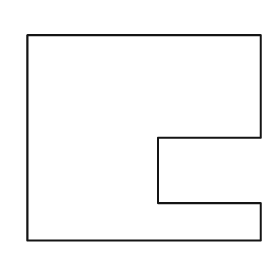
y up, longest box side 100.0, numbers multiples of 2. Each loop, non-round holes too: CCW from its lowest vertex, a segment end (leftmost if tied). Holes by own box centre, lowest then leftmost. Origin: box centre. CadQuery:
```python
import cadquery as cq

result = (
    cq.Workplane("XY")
    .moveTo(-50.0, -44.0)
    .lineTo(50.0, -44.0)
    .lineTo(50.0, -28.0)
    .lineTo(6.0, -28.0)
    .lineTo(6.0, 0.0)
    .lineTo(50.0, 0.0)
    .lineTo(50.0, 44.0)
    .lineTo(-50.0, 44.0)
    .close()
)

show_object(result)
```